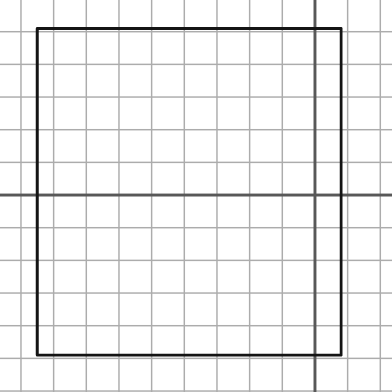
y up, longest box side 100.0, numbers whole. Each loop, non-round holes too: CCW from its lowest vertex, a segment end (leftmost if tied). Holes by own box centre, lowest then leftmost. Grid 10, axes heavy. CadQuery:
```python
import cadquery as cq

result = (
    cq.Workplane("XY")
    .moveTo(-85.0, -49.0)
    .lineTo(8.0, -49.0)
    .lineTo(8.0, 51.0)
    .lineTo(-85.0, 51.0)
    .close()
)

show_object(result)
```